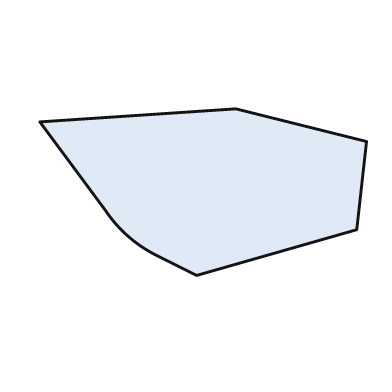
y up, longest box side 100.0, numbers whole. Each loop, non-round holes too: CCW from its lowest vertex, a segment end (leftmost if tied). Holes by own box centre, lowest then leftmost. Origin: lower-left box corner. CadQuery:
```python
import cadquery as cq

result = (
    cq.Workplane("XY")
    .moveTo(48.0, 0.0)
    .lineTo(97.0, 14.0)
    .lineTo(100.0, 41.0)
    .lineTo(60.0, 51.0)
    .lineTo(0.0, 47.0)
    .lineTo(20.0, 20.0)
    .threePointArc((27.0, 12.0), (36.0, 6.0))
    .close()
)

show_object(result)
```